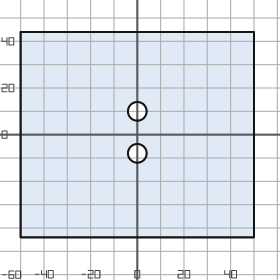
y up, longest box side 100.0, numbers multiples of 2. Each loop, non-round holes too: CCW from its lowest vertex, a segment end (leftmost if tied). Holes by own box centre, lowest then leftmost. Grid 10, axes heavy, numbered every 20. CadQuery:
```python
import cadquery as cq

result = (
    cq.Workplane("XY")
    .moveTo(-50.0, -44.0)
    .lineTo(50.0, -44.0)
    .lineTo(50.0, 44.0)
    .lineTo(-50.0, 44.0)
    .close()
    .moveTo(0.0, -8.0)
    .circle(4.0)
    .moveTo(0.0, 10.0)
    .circle(4.0)
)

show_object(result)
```